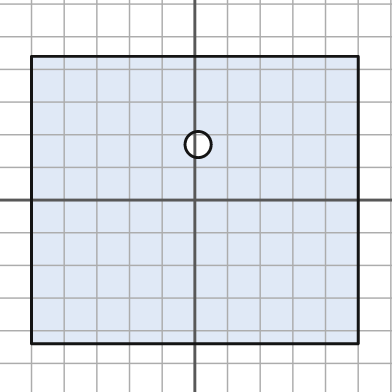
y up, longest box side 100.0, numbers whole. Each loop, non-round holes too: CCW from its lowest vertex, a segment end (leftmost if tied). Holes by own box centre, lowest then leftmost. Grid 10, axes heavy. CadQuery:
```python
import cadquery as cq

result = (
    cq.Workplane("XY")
    .moveTo(-50.0, -44.0)
    .lineTo(50.0, -44.0)
    .lineTo(50.0, 44.0)
    .lineTo(-50.0, 44.0)
    .close()
    .moveTo(1.0, 17.0)
    .circle(4.0)
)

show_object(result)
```